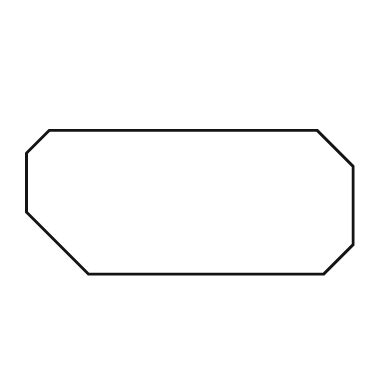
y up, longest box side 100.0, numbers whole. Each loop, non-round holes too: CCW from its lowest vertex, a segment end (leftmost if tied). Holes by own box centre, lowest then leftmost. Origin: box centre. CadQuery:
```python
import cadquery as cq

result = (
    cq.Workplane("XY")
    .moveTo(-31.0, -22.0)
    .lineTo(41.0, -22.0)
    .lineTo(50.0, -13.0)
    .lineTo(50.0, 11.0)
    .lineTo(39.0, 22.0)
    .lineTo(-43.0, 22.0)
    .lineTo(-50.0, 15.0)
    .lineTo(-50.0, -3.0)
    .close()
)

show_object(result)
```